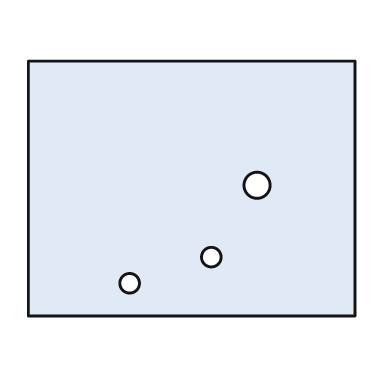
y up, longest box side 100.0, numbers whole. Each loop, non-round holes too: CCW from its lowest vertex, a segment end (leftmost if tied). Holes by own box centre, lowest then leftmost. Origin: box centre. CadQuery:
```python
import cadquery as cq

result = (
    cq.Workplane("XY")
    .moveTo(-50.0, -39.0)
    .lineTo(50.0, -39.0)
    .lineTo(50.0, 39.0)
    .lineTo(-50.0, 39.0)
    .close()
    .moveTo(-19.0, -29.0)
    .circle(3.0)
    .moveTo(6.0, -21.0)
    .circle(3.0)
    .moveTo(20.0, 1.0)
    .circle(4.0)
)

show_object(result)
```